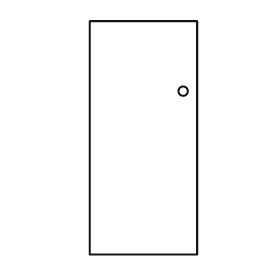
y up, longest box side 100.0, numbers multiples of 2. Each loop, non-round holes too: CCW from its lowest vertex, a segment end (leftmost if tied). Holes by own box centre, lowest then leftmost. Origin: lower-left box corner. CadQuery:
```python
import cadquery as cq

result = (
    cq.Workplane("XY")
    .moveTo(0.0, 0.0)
    .lineTo(46.0, 0.0)
    .lineTo(46.0, 100.0)
    .lineTo(0.0, 100.0)
    .close()
    .moveTo(40.0, 70.0)
    .circle(2.0)
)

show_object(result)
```